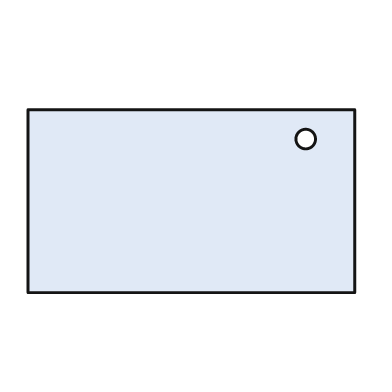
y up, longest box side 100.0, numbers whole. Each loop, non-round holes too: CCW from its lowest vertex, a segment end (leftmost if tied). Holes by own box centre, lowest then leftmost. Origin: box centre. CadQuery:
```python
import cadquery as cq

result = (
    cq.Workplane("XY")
    .moveTo(-50.0, -28.0)
    .lineTo(50.0, -28.0)
    .lineTo(50.0, 28.0)
    .lineTo(-50.0, 28.0)
    .close()
    .moveTo(35.0, 19.0)
    .circle(3.0)
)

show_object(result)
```